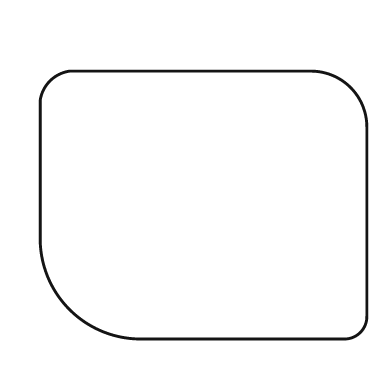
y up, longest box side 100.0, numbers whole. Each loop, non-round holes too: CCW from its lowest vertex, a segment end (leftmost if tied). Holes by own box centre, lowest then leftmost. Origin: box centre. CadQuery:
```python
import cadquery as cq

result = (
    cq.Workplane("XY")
    .moveTo(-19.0, -41.0)
    .lineTo(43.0, -41.0)
    .threePointArc((48.0, -39.0), (50.0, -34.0))
    .lineTo(50.0, 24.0)
    .threePointArc((45.0, 36.0), (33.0, 41.0))
    .lineTo(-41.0, 41.0)
    .threePointArc((-47.0, 38.0), (-50.0, 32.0))
    .lineTo(-50.0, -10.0)
    .threePointArc((-41.0, -32.0), (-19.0, -41.0))
    .close()
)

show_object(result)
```